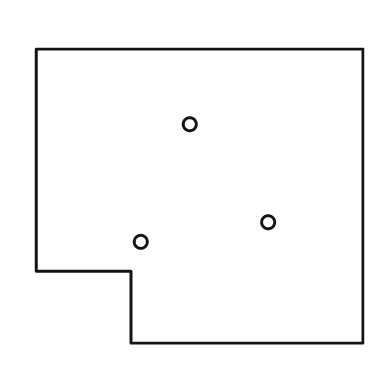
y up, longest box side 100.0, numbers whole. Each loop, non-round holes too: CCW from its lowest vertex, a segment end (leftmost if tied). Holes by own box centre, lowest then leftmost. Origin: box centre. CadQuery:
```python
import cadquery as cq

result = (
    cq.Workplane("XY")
    .moveTo(-21.0, -45.0)
    .lineTo(50.0, -45.0)
    .lineTo(50.0, 45.0)
    .lineTo(-50.0, 45.0)
    .lineTo(-50.0, -23.0)
    .lineTo(-21.0, -23.0)
    .close()
    .moveTo(-18.0, -14.0)
    .circle(2.0)
    .moveTo(21.0, -8.0)
    .circle(2.0)
    .moveTo(-3.0, 22.0)
    .circle(2.0)
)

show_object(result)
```